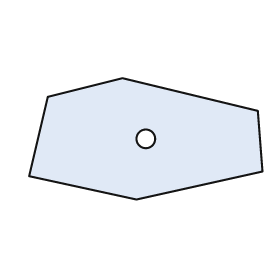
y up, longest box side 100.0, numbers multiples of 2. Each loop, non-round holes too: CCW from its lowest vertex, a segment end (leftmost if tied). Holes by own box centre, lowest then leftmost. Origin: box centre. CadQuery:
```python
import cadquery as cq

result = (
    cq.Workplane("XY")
    .moveTo(-4.0, -26.0)
    .lineTo(50.0, -14.0)
    .lineTo(48.0, 12.0)
    .lineTo(-10.0, 26.0)
    .lineTo(-42.0, 18.0)
    .lineTo(-50.0, -16.0)
    .close()
    .moveTo(0.0, 0.0)
    .circle(4.0)
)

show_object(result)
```